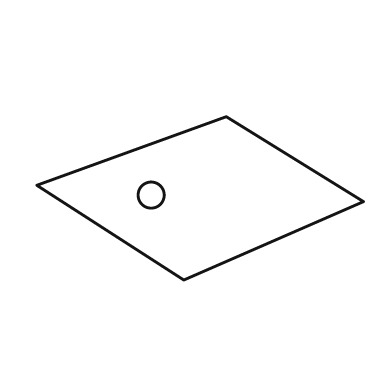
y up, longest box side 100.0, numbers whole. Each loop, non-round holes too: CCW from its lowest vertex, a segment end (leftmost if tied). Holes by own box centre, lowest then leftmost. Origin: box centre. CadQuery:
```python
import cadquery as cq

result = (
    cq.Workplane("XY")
    .moveTo(-5.0, -25.0)
    .lineTo(50.0, -1.0)
    .lineTo(8.0, 25.0)
    .lineTo(-50.0, 4.0)
    .close()
    .moveTo(-15.0, 1.0)
    .circle(4.0)
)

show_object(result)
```